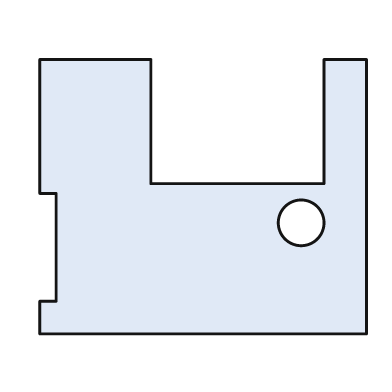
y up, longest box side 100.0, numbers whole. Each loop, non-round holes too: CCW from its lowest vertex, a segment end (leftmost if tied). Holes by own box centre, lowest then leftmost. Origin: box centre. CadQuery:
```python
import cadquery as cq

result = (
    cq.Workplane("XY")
    .moveTo(-50.0, -42.0)
    .lineTo(50.0, -42.0)
    .lineTo(50.0, 42.0)
    .lineTo(37.0, 42.0)
    .lineTo(37.0, 4.0)
    .lineTo(-16.0, 4.0)
    .lineTo(-16.0, 42.0)
    .lineTo(-50.0, 42.0)
    .lineTo(-50.0, 1.0)
    .lineTo(-45.0, 1.0)
    .lineTo(-45.0, -32.0)
    .lineTo(-50.0, -32.0)
    .close()
    .moveTo(30.0, -8.0)
    .circle(7.0)
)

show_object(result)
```